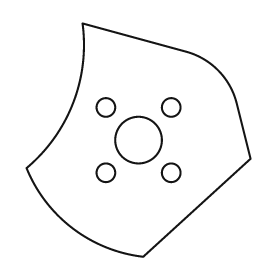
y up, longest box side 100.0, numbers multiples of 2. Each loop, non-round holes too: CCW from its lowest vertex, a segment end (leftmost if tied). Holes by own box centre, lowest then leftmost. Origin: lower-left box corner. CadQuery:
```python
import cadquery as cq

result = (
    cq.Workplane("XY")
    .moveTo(50.0, 0.0)
    .lineTo(96.0, 42.0)
    .lineTo(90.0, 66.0)
    .threePointArc((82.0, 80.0), (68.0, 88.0))
    .lineTo(24.0, 100.0)
    .threePointArc((20.0, 66.0), (0.0, 38.0))
    .threePointArc((20.0, 12.0), (50.0, 0.0))
    .close()
    .moveTo(34.0, 36.0)
    .circle(4.0)
    .moveTo(62.0, 36.0)
    .circle(4.0)
    .moveTo(48.0, 50.0)
    .circle(10.0)
    .moveTo(34.0, 64.0)
    .circle(4.0)
    .moveTo(62.0, 64.0)
    .circle(4.0)
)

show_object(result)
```